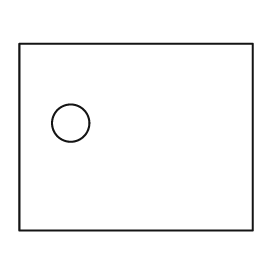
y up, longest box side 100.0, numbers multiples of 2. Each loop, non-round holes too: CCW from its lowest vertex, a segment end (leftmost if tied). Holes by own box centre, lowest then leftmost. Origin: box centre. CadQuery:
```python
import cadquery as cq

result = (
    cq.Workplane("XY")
    .moveTo(-50.0, -40.0)
    .lineTo(50.0, -40.0)
    .lineTo(50.0, 40.0)
    .lineTo(-50.0, 40.0)
    .close()
    .moveTo(-28.0, 6.0)
    .circle(8.0)
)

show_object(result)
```